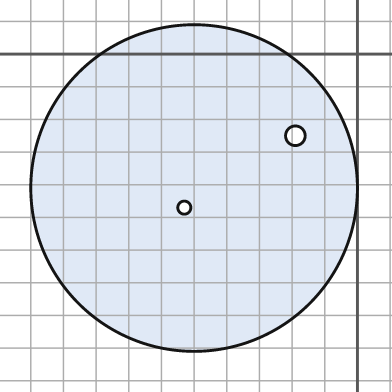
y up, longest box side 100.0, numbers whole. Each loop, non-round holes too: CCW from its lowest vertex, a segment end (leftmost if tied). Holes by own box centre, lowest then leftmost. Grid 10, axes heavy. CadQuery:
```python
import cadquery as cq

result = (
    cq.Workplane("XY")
    .moveTo(-50.0, -41.0)
    .circle(50.0)
    .moveTo(-53.0, -47.0)
    .circle(2.0)
    .moveTo(-19.0, -25.0)
    .circle(3.0)
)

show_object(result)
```